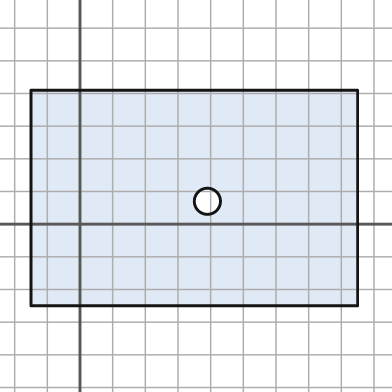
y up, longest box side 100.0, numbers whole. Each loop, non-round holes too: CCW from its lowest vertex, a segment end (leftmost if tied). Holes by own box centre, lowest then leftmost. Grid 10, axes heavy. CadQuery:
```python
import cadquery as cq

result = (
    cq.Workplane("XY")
    .moveTo(-15.0, -25.0)
    .lineTo(85.0, -25.0)
    .lineTo(85.0, 41.0)
    .lineTo(-15.0, 41.0)
    .close()
    .moveTo(39.0, 7.0)
    .circle(4.0)
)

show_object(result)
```